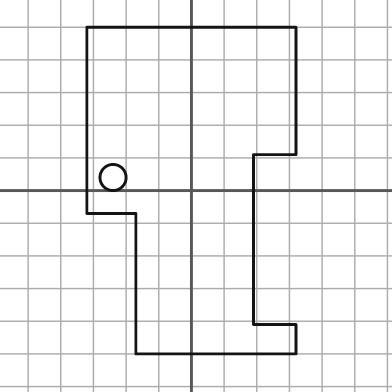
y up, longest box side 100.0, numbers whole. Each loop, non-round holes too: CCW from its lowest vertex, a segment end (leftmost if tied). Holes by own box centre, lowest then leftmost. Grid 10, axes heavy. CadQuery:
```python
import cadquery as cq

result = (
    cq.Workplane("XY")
    .moveTo(-17.0, -50.0)
    .lineTo(32.0, -50.0)
    .lineTo(32.0, -41.0)
    .lineTo(19.0, -41.0)
    .lineTo(19.0, 11.0)
    .lineTo(32.0, 11.0)
    .lineTo(32.0, 50.0)
    .lineTo(-32.0, 50.0)
    .lineTo(-32.0, -7.0)
    .lineTo(-17.0, -7.0)
    .close()
    .moveTo(-24.0, 4.0)
    .circle(4.0)
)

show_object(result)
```